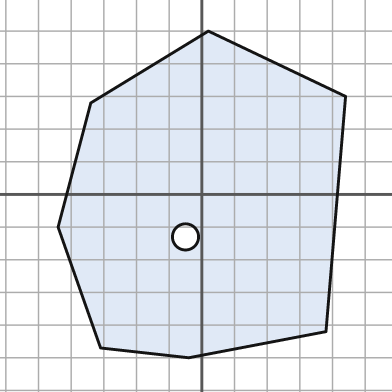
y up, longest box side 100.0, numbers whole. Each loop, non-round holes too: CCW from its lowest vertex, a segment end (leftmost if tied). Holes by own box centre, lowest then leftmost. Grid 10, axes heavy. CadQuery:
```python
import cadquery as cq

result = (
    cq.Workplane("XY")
    .moveTo(-4.0, -50.0)
    .lineTo(38.0, -42.0)
    .lineTo(44.0, 30.0)
    .lineTo(2.0, 50.0)
    .lineTo(-34.0, 28.0)
    .lineTo(-44.0, -10.0)
    .lineTo(-31.0, -47.0)
    .close()
    .moveTo(-5.0, -13.0)
    .circle(4.0)
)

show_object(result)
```